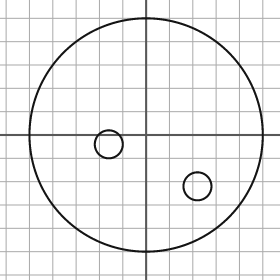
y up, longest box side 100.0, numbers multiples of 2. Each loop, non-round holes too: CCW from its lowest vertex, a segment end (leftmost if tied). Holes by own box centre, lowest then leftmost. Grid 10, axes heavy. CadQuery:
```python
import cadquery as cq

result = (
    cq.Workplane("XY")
    .moveTo(0.0, 0.0)
    .circle(50.0)
    .moveTo(22.0, -22.0)
    .circle(6.0)
    .moveTo(-16.0, -4.0)
    .circle(6.0)
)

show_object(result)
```